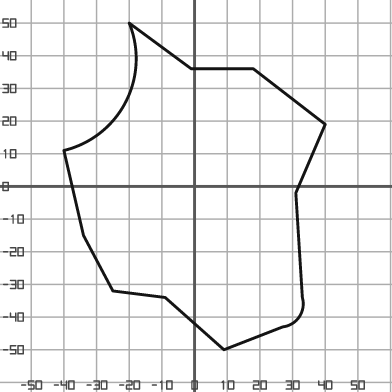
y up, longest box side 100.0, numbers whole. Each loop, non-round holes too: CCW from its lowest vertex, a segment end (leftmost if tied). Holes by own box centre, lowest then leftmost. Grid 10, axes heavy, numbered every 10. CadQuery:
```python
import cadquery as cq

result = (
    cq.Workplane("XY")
    .moveTo(9.0, -50.0)
    .lineTo(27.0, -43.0)
    .threePointArc((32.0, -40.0), (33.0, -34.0))
    .lineTo(31.0, -2.0)
    .lineTo(40.0, 19.0)
    .lineTo(18.0, 36.0)
    .lineTo(-1.0, 36.0)
    .lineTo(-20.0, 50.0)
    .threePointArc((-21.0, 26.0), (-40.0, 11.0))
    .lineTo(-34.0, -15.0)
    .lineTo(-25.0, -32.0)
    .lineTo(-9.0, -34.0)
    .close()
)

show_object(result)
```